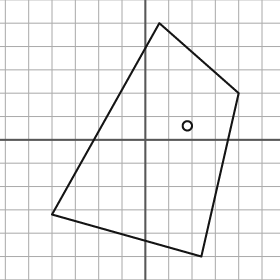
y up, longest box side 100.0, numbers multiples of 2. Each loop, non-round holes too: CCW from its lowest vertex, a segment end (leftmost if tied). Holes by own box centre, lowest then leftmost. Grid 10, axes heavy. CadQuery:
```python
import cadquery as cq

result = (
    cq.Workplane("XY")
    .moveTo(24.0, -50.0)
    .lineTo(40.0, 20.0)
    .lineTo(6.0, 50.0)
    .lineTo(-40.0, -32.0)
    .close()
    .moveTo(18.0, 6.0)
    .circle(2.0)
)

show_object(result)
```